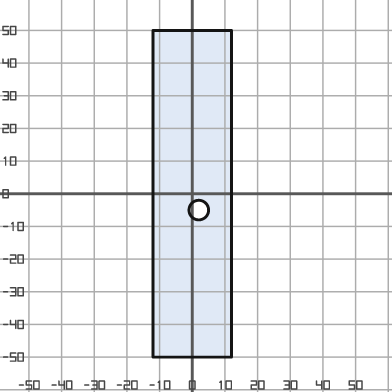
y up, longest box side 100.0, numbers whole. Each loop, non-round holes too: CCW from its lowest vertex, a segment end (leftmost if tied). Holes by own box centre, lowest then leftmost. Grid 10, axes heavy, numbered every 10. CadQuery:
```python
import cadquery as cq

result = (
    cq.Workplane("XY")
    .moveTo(-12.0, -50.0)
    .lineTo(12.0, -50.0)
    .lineTo(12.0, 50.0)
    .lineTo(-12.0, 50.0)
    .close()
    .moveTo(2.0, -5.0)
    .circle(3.0)
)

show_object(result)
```